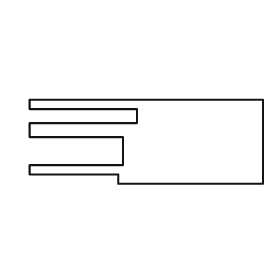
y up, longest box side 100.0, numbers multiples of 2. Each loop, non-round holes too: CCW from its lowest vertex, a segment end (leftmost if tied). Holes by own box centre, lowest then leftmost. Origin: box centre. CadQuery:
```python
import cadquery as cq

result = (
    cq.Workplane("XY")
    .moveTo(-12.0, -18.0)
    .lineTo(50.0, -18.0)
    .lineTo(50.0, 18.0)
    .lineTo(-50.0, 18.0)
    .lineTo(-50.0, 14.0)
    .lineTo(-4.0, 14.0)
    .lineTo(-4.0, 8.0)
    .lineTo(-50.0, 8.0)
    .lineTo(-50.0, 2.0)
    .lineTo(-10.0, 2.0)
    .lineTo(-10.0, -10.0)
    .lineTo(-50.0, -10.0)
    .lineTo(-50.0, -14.0)
    .lineTo(-12.0, -14.0)
    .close()
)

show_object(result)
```